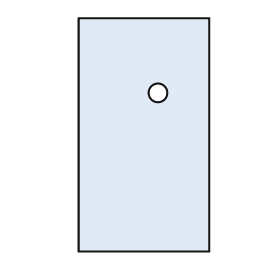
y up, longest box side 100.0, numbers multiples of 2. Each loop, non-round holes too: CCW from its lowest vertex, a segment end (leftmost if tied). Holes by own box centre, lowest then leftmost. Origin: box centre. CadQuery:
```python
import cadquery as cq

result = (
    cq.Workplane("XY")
    .moveTo(-28.0, -50.0)
    .lineTo(28.0, -50.0)
    .lineTo(28.0, 50.0)
    .lineTo(-28.0, 50.0)
    .close()
    .moveTo(6.0, 18.0)
    .circle(4.0)
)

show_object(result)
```